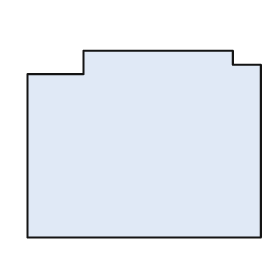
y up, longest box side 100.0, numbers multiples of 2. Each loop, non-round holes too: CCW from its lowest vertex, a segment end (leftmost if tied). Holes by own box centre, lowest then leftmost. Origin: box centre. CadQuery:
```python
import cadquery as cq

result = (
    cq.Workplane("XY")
    .moveTo(-50.0, -40.0)
    .lineTo(50.0, -40.0)
    .lineTo(50.0, 34.0)
    .lineTo(38.0, 34.0)
    .lineTo(38.0, 40.0)
    .lineTo(-26.0, 40.0)
    .lineTo(-26.0, 30.0)
    .lineTo(-50.0, 30.0)
    .close()
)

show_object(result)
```